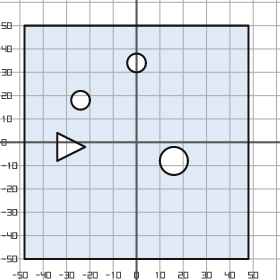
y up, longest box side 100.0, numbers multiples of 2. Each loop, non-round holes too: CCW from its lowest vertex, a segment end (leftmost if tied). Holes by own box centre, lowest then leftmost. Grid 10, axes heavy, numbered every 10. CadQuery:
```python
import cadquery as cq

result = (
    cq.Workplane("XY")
    .moveTo(-48.0, -50.0)
    .lineTo(48.0, -50.0)
    .lineTo(48.0, 50.0)
    .lineTo(-48.0, 50.0)
    .close()
    .moveTo(16.0, -8.0)
    .circle(6.0)
    .moveTo(-34.0, -8.0)
    .lineTo(-22.0, -2.0)
    .lineTo(-34.0, 4.0)
    .close()
    .moveTo(-24.0, 18.0)
    .circle(4.0)
    .moveTo(0.0, 34.0)
    .circle(4.0)
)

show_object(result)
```